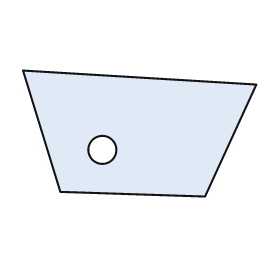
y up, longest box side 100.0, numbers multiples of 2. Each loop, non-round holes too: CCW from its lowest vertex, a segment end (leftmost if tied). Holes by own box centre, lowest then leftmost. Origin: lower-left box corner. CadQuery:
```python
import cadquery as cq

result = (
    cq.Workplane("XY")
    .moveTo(78.0, 0.0)
    .lineTo(100.0, 48.0)
    .lineTo(0.0, 54.0)
    .lineTo(16.0, 2.0)
    .close()
    .moveTo(34.0, 20.0)
    .circle(6.0)
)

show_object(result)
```